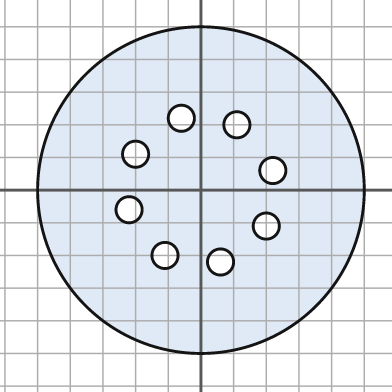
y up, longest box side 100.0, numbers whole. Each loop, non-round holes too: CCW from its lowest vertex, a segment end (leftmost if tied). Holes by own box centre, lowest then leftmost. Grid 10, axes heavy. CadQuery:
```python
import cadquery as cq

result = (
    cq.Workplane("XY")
    .moveTo(0.0, 0.0)
    .circle(50.0)
    .moveTo(6.0, -22.0)
    .circle(4.0)
    .moveTo(-11.0, -20.0)
    .circle(4.0)
    .moveTo(20.0, -11.0)
    .circle(4.0)
    .moveTo(-22.0, -6.0)
    .circle(4.0)
    .moveTo(22.0, 6.0)
    .circle(4.0)
    .moveTo(-20.0, 11.0)
    .circle(4.0)
    .moveTo(11.0, 20.0)
    .circle(4.0)
    .moveTo(-6.0, 22.0)
    .circle(4.0)
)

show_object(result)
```